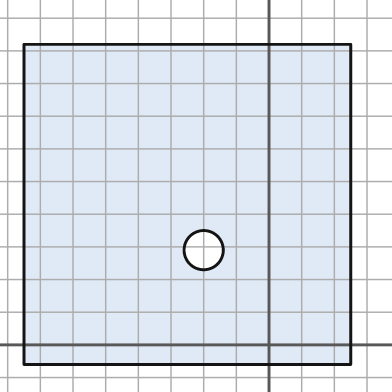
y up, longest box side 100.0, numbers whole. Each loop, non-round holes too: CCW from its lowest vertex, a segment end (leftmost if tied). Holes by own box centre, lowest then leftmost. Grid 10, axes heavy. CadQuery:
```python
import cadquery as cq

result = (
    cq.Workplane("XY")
    .moveTo(-75.0, -6.0)
    .lineTo(25.0, -6.0)
    .lineTo(25.0, 92.0)
    .lineTo(-75.0, 92.0)
    .close()
    .moveTo(-20.0, 29.0)
    .circle(6.0)
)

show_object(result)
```